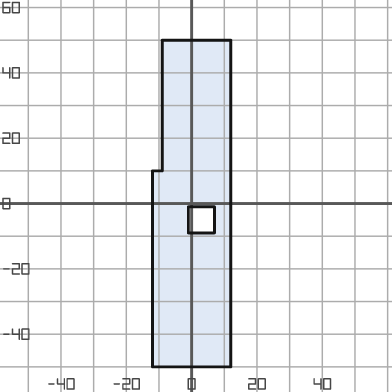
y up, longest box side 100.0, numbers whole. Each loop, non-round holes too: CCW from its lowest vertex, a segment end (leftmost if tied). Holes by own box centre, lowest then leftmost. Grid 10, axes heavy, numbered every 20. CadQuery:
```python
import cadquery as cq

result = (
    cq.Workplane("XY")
    .moveTo(-12.0, -50.0)
    .lineTo(12.0, -50.0)
    .lineTo(12.0, 50.0)
    .lineTo(-9.0, 50.0)
    .lineTo(-9.0, 10.0)
    .lineTo(-12.0, 10.0)
    .close()
    .moveTo(-1.0, -9.0)
    .lineTo(7.0, -9.0)
    .lineTo(7.0, -1.0)
    .lineTo(-1.0, -1.0)
    .close()
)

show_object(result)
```